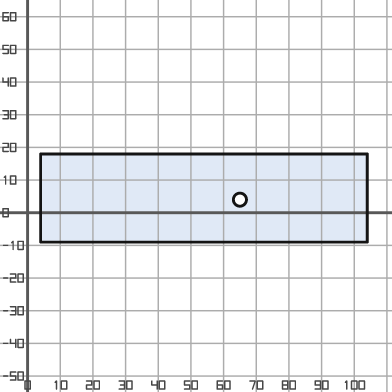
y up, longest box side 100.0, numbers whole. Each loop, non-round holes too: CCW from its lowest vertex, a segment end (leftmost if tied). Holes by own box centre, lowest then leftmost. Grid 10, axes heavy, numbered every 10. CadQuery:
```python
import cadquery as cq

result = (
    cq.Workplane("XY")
    .moveTo(4.0, -9.0)
    .lineTo(104.0, -9.0)
    .lineTo(104.0, 18.0)
    .lineTo(4.0, 18.0)
    .close()
    .moveTo(65.0, 4.0)
    .circle(2.0)
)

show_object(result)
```